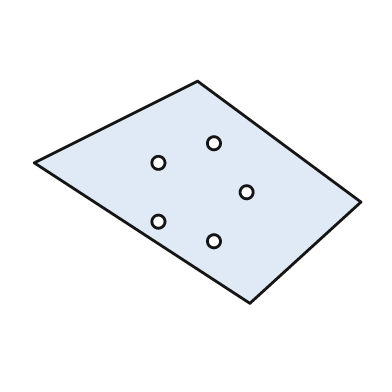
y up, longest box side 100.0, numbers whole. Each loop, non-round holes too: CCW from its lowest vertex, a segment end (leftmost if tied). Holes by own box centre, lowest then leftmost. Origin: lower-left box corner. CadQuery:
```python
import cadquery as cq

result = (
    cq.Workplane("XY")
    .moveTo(66.0, 0.0)
    .lineTo(100.0, 31.0)
    .lineTo(50.0, 68.0)
    .lineTo(0.0, 43.0)
    .close()
    .moveTo(55.0, 19.0)
    .circle(2.0)
    .moveTo(38.0, 25.0)
    .circle(2.0)
    .moveTo(65.0, 34.0)
    .circle(2.0)
    .moveTo(38.0, 43.0)
    .circle(2.0)
    .moveTo(55.0, 49.0)
    .circle(2.0)
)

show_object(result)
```